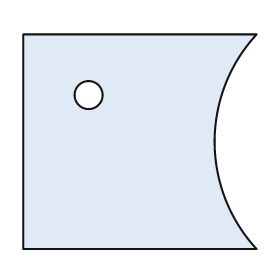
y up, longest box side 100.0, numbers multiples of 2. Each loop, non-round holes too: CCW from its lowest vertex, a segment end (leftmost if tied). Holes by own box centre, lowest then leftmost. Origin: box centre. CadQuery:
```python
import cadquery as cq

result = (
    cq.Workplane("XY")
    .moveTo(-50.0, -46.0)
    .lineTo(50.0, -46.0)
    .threePointArc((32.0, 0.0), (50.0, 46.0))
    .lineTo(-50.0, 46.0)
    .close()
    .moveTo(-22.0, 20.0)
    .circle(6.0)
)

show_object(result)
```